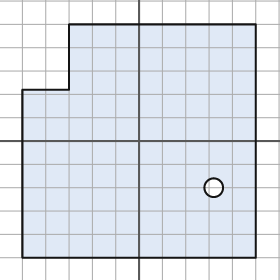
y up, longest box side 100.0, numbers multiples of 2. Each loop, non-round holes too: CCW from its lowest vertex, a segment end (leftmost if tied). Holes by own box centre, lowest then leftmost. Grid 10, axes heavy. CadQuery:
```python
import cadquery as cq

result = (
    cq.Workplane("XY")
    .moveTo(-50.0, -50.0)
    .lineTo(50.0, -50.0)
    .lineTo(50.0, 50.0)
    .lineTo(-30.0, 50.0)
    .lineTo(-30.0, 22.0)
    .lineTo(-50.0, 22.0)
    .close()
    .moveTo(32.0, -20.0)
    .circle(4.0)
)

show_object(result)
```